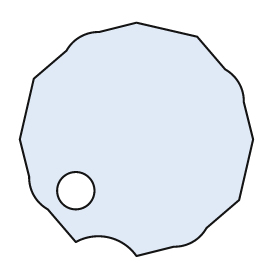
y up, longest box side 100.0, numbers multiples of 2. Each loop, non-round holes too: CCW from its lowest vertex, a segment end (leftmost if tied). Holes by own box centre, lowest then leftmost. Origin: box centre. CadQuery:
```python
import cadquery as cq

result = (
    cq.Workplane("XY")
    .moveTo(0.0, -50.0)
    .lineTo(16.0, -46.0)
    .threePointArc((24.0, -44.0), (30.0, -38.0))
    .lineTo(44.0, -26.0)
    .lineTo(50.0, 0.0)
    .lineTo(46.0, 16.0)
    .threePointArc((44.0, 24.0), (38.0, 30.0))
    .lineTo(26.0, 44.0)
    .lineTo(0.0, 50.0)
    .lineTo(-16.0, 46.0)
    .threePointArc((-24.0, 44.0), (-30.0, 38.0))
    .lineTo(-44.0, 26.0)
    .lineTo(-50.0, 0.0)
    .lineTo(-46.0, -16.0)
    .threePointArc((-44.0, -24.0), (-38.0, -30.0))
    .lineTo(-26.0, -44.0)
    .threePointArc((-12.0, -42.0), (0.0, -50.0))
    .close()
    .moveTo(-26.0, -22.0)
    .circle(8.0)
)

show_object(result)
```